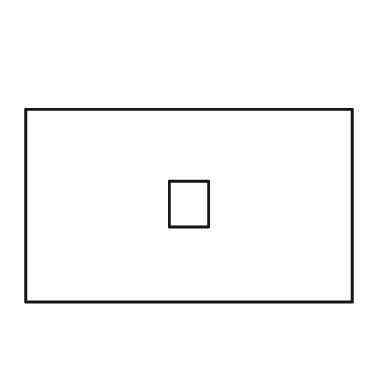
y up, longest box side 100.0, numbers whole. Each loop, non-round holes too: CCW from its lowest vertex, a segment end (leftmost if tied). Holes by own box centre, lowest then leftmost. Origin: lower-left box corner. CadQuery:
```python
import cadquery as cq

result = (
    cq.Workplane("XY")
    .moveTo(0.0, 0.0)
    .lineTo(100.0, 0.0)
    .lineTo(100.0, 59.0)
    .lineTo(0.0, 59.0)
    .close()
    .moveTo(44.0, 23.0)
    .lineTo(56.0, 23.0)
    .lineTo(56.0, 37.0)
    .lineTo(44.0, 37.0)
    .close()
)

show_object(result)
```